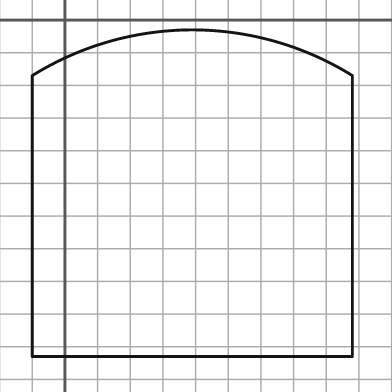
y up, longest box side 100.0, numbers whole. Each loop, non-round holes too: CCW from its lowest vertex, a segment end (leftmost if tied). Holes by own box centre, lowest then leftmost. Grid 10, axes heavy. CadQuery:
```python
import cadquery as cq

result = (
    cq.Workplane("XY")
    .moveTo(-10.0, -103.0)
    .lineTo(88.0, -103.0)
    .lineTo(88.0, -17.0)
    .threePointArc((39.0, -3.0), (-10.0, -17.0))
    .close()
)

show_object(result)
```